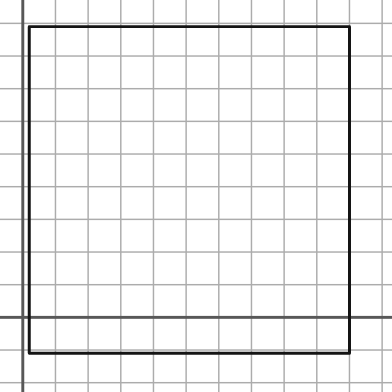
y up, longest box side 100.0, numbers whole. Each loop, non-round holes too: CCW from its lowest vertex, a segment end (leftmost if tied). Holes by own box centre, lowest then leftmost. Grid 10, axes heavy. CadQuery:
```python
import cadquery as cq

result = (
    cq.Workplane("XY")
    .moveTo(2.0, -11.0)
    .lineTo(100.0, -11.0)
    .lineTo(100.0, 89.0)
    .lineTo(2.0, 89.0)
    .close()
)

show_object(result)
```